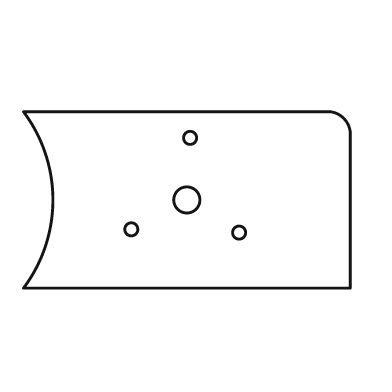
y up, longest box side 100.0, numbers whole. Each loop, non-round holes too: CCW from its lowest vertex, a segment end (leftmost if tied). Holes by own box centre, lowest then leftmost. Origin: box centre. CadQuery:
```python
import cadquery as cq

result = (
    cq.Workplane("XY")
    .moveTo(-50.0, -27.0)
    .lineTo(50.0, -27.0)
    .lineTo(50.0, 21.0)
    .threePointArc((48.0, 25.0), (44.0, 27.0))
    .lineTo(-50.0, 27.0)
    .threePointArc((-41.0, 0.0), (-50.0, -27.0))
    .close()
    .moveTo(16.0, -10.0)
    .circle(2.0)
    .moveTo(-17.0, -9.0)
    .circle(2.0)
    .moveTo(0.0, 0.0)
    .circle(4.0)
    .moveTo(1.0, 19.0)
    .circle(2.0)
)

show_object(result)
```